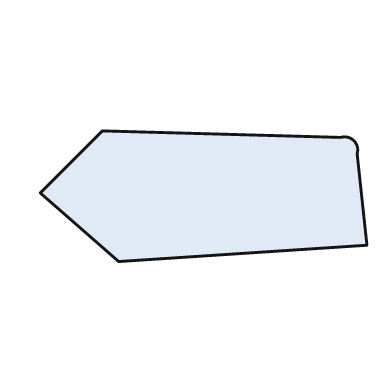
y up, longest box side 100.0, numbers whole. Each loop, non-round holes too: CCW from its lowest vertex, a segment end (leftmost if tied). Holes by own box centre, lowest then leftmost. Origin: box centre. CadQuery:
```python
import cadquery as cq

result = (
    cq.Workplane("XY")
    .moveTo(-26.0, -20.0)
    .lineTo(50.0, -15.0)
    .lineTo(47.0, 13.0)
    .threePointArc((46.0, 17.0), (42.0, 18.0))
    .lineTo(-31.0, 20.0)
    .lineTo(-50.0, 1.0)
    .close()
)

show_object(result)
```